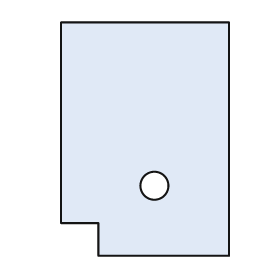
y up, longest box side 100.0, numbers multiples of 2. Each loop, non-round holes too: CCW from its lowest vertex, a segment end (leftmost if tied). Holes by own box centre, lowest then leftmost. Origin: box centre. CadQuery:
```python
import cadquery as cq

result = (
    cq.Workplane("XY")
    .moveTo(-20.0, -50.0)
    .lineTo(36.0, -50.0)
    .lineTo(36.0, 50.0)
    .lineTo(-36.0, 50.0)
    .lineTo(-36.0, -36.0)
    .lineTo(-20.0, -36.0)
    .close()
    .moveTo(4.0, -20.0)
    .circle(6.0)
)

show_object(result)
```